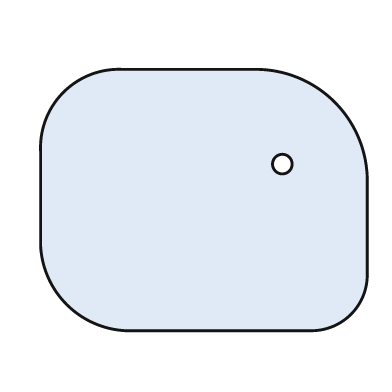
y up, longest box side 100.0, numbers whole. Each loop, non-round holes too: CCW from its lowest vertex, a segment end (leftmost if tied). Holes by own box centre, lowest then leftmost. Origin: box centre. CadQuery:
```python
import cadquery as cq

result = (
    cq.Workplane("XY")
    .moveTo(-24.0, -40.0)
    .lineTo(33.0, -40.0)
    .threePointArc((45.0, -35.0), (50.0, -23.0))
    .lineTo(50.0, 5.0)
    .threePointArc((40.0, 30.0), (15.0, 40.0))
    .lineTo(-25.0, 40.0)
    .threePointArc((-43.0, 33.0), (-50.0, 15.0))
    .lineTo(-50.0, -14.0)
    .threePointArc((-42.0, -32.0), (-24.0, -40.0))
    .close()
    .moveTo(24.0, 11.0)
    .circle(3.0)
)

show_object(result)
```